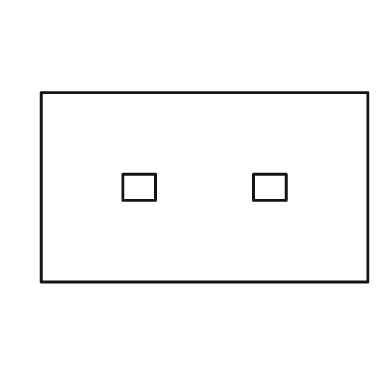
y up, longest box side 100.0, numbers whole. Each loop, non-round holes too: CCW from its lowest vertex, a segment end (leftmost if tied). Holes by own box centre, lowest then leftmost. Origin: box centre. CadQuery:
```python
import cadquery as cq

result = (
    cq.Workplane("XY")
    .moveTo(-50.0, -29.0)
    .lineTo(50.0, -29.0)
    .lineTo(50.0, 29.0)
    .lineTo(-50.0, 29.0)
    .close()
    .moveTo(-25.0, -4.0)
    .lineTo(-15.0, -4.0)
    .lineTo(-15.0, 4.0)
    .lineTo(-25.0, 4.0)
    .close()
    .moveTo(15.0, -4.0)
    .lineTo(25.0, -4.0)
    .lineTo(25.0, 4.0)
    .lineTo(15.0, 4.0)
    .close()
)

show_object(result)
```